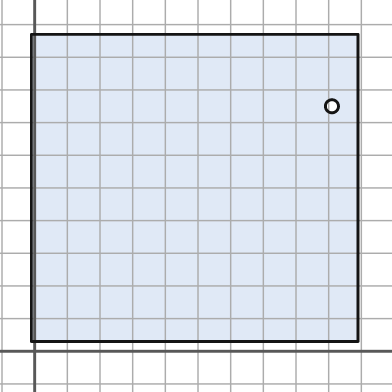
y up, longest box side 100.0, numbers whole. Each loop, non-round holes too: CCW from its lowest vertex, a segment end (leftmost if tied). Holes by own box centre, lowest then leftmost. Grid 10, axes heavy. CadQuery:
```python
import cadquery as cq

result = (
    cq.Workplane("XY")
    .moveTo(-1.0, 3.0)
    .lineTo(99.0, 3.0)
    .lineTo(99.0, 97.0)
    .lineTo(-1.0, 97.0)
    .close()
    .moveTo(91.0, 75.0)
    .circle(2.0)
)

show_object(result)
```